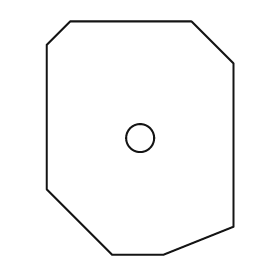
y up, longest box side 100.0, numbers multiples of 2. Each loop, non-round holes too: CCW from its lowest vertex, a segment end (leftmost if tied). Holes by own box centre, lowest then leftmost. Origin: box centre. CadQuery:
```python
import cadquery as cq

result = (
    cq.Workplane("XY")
    .moveTo(-12.0, -50.0)
    .lineTo(10.0, -50.0)
    .lineTo(40.0, -38.0)
    .lineTo(40.0, 32.0)
    .lineTo(22.0, 50.0)
    .lineTo(-30.0, 50.0)
    .lineTo(-40.0, 40.0)
    .lineTo(-40.0, -22.0)
    .close()
    .moveTo(0.0, 0.0)
    .circle(6.0)
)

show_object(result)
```